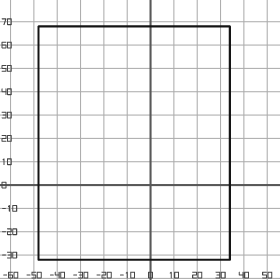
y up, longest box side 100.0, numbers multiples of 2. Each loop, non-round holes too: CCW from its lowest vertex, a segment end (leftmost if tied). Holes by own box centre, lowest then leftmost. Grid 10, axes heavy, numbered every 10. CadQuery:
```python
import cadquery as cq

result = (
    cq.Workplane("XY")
    .moveTo(-48.0, -32.0)
    .lineTo(34.0, -32.0)
    .lineTo(34.0, 68.0)
    .lineTo(-48.0, 68.0)
    .close()
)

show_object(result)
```